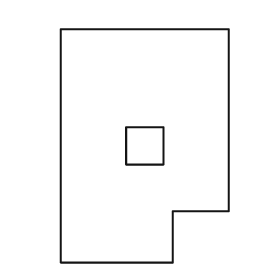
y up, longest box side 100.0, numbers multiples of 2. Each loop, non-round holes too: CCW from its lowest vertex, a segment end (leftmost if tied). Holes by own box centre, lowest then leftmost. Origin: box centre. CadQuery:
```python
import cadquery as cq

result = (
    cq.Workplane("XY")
    .moveTo(-36.0, -50.0)
    .lineTo(12.0, -50.0)
    .lineTo(12.0, -28.0)
    .lineTo(36.0, -28.0)
    .lineTo(36.0, 50.0)
    .lineTo(-36.0, 50.0)
    .close()
    .moveTo(-8.0, -8.0)
    .lineTo(8.0, -8.0)
    .lineTo(8.0, 8.0)
    .lineTo(-8.0, 8.0)
    .close()
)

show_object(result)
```